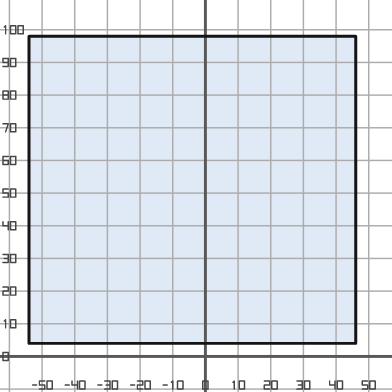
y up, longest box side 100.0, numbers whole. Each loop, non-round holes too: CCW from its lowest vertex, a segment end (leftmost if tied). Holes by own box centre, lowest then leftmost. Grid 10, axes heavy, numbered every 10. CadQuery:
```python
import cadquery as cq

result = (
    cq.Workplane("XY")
    .moveTo(-54.0, 4.0)
    .lineTo(46.0, 4.0)
    .lineTo(46.0, 98.0)
    .lineTo(-54.0, 98.0)
    .close()
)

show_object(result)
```